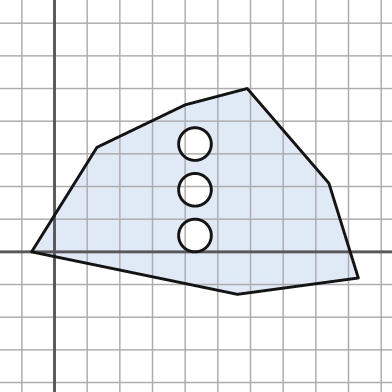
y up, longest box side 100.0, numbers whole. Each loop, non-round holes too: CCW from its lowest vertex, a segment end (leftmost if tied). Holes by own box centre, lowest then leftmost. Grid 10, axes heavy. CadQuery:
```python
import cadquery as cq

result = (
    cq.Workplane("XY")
    .moveTo(56.0, -13.0)
    .lineTo(93.0, -8.0)
    .lineTo(84.0, 21.0)
    .lineTo(59.0, 50.0)
    .lineTo(40.0, 45.0)
    .lineTo(13.0, 32.0)
    .lineTo(-7.0, 0.0)
    .close()
    .moveTo(43.0, 5.0)
    .circle(5.0)
    .moveTo(43.0, 19.0)
    .circle(5.0)
    .moveTo(43.0, 33.0)
    .circle(5.0)
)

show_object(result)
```